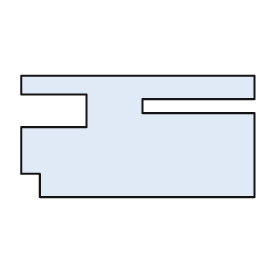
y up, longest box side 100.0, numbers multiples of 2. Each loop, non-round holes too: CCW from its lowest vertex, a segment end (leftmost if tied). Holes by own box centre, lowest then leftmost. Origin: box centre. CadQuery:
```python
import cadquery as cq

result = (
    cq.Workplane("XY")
    .moveTo(-42.0, -26.0)
    .lineTo(50.0, -26.0)
    .lineTo(50.0, 10.0)
    .lineTo(2.0, 10.0)
    .lineTo(2.0, 16.0)
    .lineTo(50.0, 16.0)
    .lineTo(50.0, 26.0)
    .lineTo(-50.0, 26.0)
    .lineTo(-50.0, 18.0)
    .lineTo(-22.0, 18.0)
    .lineTo(-22.0, 4.0)
    .lineTo(-50.0, 4.0)
    .lineTo(-50.0, -16.0)
    .lineTo(-42.0, -16.0)
    .close()
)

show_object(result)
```